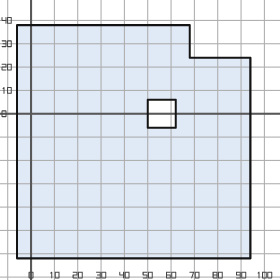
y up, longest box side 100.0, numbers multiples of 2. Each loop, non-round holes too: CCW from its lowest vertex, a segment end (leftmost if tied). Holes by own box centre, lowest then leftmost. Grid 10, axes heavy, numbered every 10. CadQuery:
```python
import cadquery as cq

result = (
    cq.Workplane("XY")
    .moveTo(-6.0, -62.0)
    .lineTo(94.0, -62.0)
    .lineTo(94.0, 24.0)
    .lineTo(68.0, 24.0)
    .lineTo(68.0, 38.0)
    .lineTo(-6.0, 38.0)
    .close()
    .moveTo(50.0, -6.0)
    .lineTo(62.0, -6.0)
    .lineTo(62.0, 6.0)
    .lineTo(50.0, 6.0)
    .close()
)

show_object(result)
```